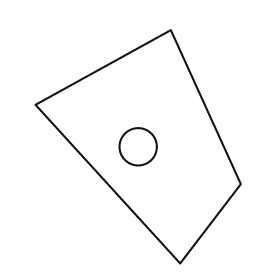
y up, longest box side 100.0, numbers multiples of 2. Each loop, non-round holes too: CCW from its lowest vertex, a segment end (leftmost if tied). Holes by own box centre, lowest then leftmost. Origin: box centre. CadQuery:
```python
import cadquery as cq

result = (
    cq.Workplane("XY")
    .moveTo(18.0, -50.0)
    .lineTo(44.0, -16.0)
    .lineTo(14.0, 50.0)
    .lineTo(-44.0, 18.0)
    .close()
    .moveTo(0.0, 0.0)
    .circle(8.0)
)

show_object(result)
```